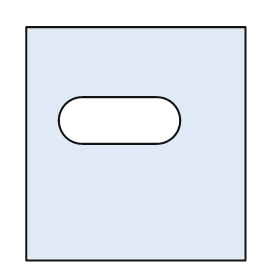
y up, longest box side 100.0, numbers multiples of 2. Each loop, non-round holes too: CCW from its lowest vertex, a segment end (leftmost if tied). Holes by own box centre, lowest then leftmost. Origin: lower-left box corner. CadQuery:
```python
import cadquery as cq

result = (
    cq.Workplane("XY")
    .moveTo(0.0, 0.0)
    .lineTo(94.0, 0.0)
    .lineTo(94.0, 100.0)
    .lineTo(0.0, 100.0)
    .close()
    .moveTo(24.0, 50.0)
    .lineTo(56.0, 50.0)
    .threePointArc((66.0, 60.0), (56.0, 70.0))
    .lineTo(24.0, 70.0)
    .threePointArc((14.0, 60.0), (24.0, 50.0))
    .close()
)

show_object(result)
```